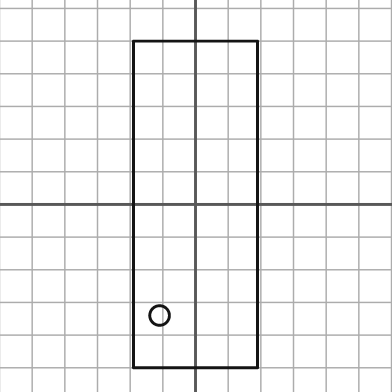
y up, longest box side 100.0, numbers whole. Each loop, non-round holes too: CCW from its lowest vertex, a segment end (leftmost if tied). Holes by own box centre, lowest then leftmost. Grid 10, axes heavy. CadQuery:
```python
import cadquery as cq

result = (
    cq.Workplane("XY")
    .moveTo(-19.0, -50.0)
    .lineTo(19.0, -50.0)
    .lineTo(19.0, 50.0)
    .lineTo(-19.0, 50.0)
    .close()
    .moveTo(-11.0, -34.0)
    .circle(3.0)
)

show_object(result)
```